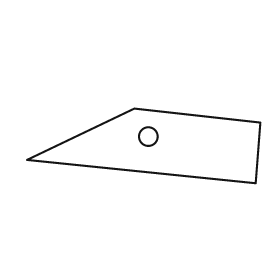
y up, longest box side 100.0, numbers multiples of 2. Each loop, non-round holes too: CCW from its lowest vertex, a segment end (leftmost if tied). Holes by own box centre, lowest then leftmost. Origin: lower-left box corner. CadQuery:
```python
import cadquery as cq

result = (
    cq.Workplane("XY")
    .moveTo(98.0, 0.0)
    .lineTo(100.0, 26.0)
    .lineTo(46.0, 32.0)
    .lineTo(0.0, 10.0)
    .close()
    .moveTo(52.0, 20.0)
    .circle(4.0)
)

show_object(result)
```